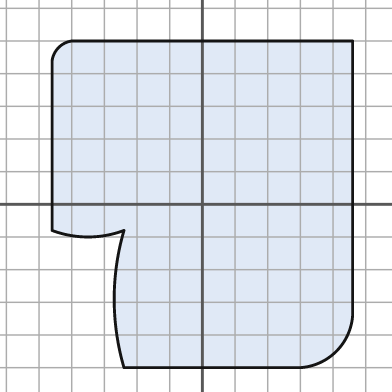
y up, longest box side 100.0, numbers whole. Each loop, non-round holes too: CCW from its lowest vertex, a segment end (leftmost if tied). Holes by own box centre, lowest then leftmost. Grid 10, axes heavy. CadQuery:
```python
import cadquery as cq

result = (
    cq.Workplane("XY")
    .moveTo(-24.0, -50.0)
    .lineTo(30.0, -50.0)
    .threePointArc((41.0, -45.0), (46.0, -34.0))
    .lineTo(46.0, 50.0)
    .lineTo(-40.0, 50.0)
    .threePointArc((-44.0, 48.0), (-46.0, 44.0))
    .lineTo(-46.0, -8.0)
    .threePointArc((-35.0, -10.0), (-24.0, -8.0))
    .threePointArc((-27.0, -29.0), (-24.0, -50.0))
    .close()
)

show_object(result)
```